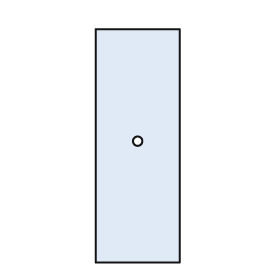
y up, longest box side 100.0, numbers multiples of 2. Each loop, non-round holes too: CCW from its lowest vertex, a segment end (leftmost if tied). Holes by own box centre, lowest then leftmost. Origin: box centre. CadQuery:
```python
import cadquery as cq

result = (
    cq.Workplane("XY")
    .moveTo(-18.0, -50.0)
    .lineTo(18.0, -50.0)
    .lineTo(18.0, 50.0)
    .lineTo(-18.0, 50.0)
    .close()
    .moveTo(0.0, 2.0)
    .circle(2.0)
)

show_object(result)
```